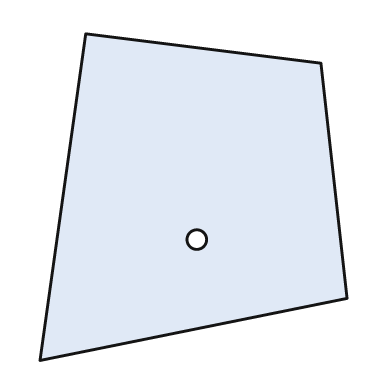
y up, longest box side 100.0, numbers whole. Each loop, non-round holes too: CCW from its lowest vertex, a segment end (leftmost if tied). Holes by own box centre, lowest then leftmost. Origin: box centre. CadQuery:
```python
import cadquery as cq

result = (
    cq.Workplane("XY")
    .moveTo(-47.0, -50.0)
    .lineTo(47.0, -31.0)
    .lineTo(39.0, 41.0)
    .lineTo(-33.0, 50.0)
    .close()
    .moveTo(1.0, -13.0)
    .circle(3.0)
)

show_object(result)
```